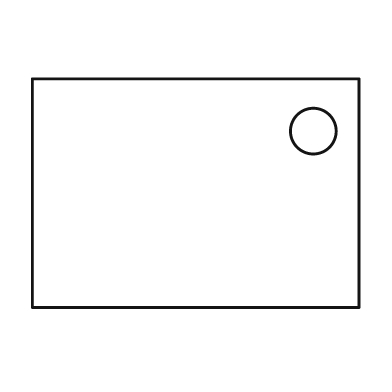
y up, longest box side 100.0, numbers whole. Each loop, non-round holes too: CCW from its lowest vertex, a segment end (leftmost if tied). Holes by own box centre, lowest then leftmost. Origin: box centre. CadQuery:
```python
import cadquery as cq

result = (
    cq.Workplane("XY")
    .moveTo(-50.0, -35.0)
    .lineTo(50.0, -35.0)
    .lineTo(50.0, 35.0)
    .lineTo(-50.0, 35.0)
    .close()
    .moveTo(36.0, 19.0)
    .circle(7.0)
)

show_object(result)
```